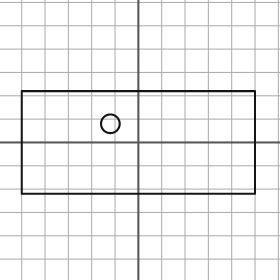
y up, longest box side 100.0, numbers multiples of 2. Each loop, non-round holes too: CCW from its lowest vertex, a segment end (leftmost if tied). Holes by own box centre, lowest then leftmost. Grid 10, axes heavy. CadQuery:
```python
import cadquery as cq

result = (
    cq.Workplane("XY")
    .moveTo(-50.0, -22.0)
    .lineTo(50.0, -22.0)
    .lineTo(50.0, 22.0)
    .lineTo(-50.0, 22.0)
    .close()
    .moveTo(-12.0, 8.0)
    .circle(4.0)
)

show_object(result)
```